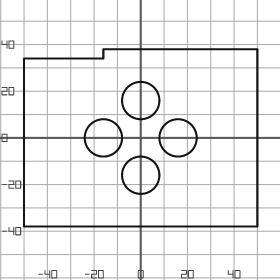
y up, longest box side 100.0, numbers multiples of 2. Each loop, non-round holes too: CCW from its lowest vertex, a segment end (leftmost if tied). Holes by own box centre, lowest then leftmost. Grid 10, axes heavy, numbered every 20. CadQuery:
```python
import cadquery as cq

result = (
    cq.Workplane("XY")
    .moveTo(-50.0, -38.0)
    .lineTo(50.0, -38.0)
    .lineTo(50.0, 38.0)
    .lineTo(-16.0, 38.0)
    .lineTo(-16.0, 34.0)
    .lineTo(-50.0, 34.0)
    .close()
    .moveTo(0.0, -16.0)
    .circle(8.0)
    .moveTo(-16.0, 0.0)
    .circle(8.0)
    .moveTo(16.0, 0.0)
    .circle(8.0)
    .moveTo(0.0, 16.0)
    .circle(8.0)
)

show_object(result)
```